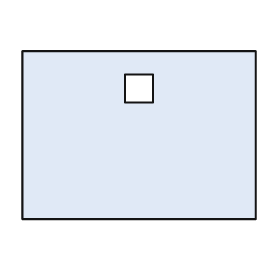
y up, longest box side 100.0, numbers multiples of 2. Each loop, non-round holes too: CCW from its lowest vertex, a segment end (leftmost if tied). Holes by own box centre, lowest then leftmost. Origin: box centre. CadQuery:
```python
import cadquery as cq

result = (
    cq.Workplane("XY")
    .moveTo(-50.0, -36.0)
    .lineTo(50.0, -36.0)
    .lineTo(50.0, 36.0)
    .lineTo(-50.0, 36.0)
    .close()
    .moveTo(-6.0, 14.0)
    .lineTo(6.0, 14.0)
    .lineTo(6.0, 26.0)
    .lineTo(-6.0, 26.0)
    .close()
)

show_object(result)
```